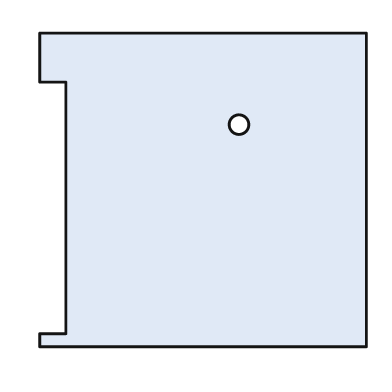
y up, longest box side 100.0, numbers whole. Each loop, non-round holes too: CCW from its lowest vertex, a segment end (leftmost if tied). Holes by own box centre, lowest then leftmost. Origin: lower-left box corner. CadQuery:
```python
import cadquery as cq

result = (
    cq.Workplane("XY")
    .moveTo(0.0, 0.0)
    .lineTo(100.0, 0.0)
    .lineTo(100.0, 96.0)
    .lineTo(0.0, 96.0)
    .lineTo(0.0, 81.0)
    .lineTo(8.0, 81.0)
    .lineTo(8.0, 4.0)
    .lineTo(0.0, 4.0)
    .close()
    .moveTo(61.0, 68.0)
    .circle(3.0)
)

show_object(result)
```